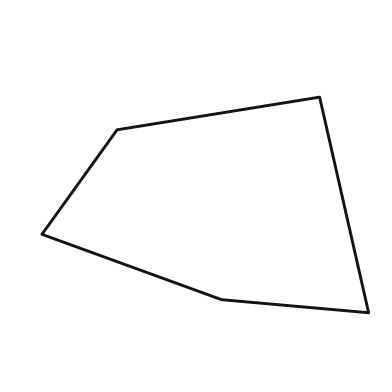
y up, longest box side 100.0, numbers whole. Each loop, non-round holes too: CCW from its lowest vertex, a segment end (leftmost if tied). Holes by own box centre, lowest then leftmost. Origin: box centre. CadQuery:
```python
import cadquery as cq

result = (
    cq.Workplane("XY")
    .moveTo(50.0, -33.0)
    .lineTo(35.0, 33.0)
    .lineTo(-27.0, 23.0)
    .lineTo(-50.0, -9.0)
    .lineTo(5.0, -29.0)
    .close()
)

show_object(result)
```